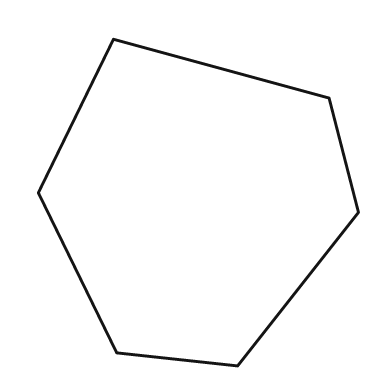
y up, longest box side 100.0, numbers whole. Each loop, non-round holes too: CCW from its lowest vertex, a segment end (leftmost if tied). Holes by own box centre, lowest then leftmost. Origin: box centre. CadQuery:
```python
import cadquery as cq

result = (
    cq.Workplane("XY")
    .moveTo(12.0, -50.0)
    .lineTo(49.0, -3.0)
    .lineTo(40.0, 32.0)
    .lineTo(-26.0, 50.0)
    .lineTo(-49.0, 3.0)
    .lineTo(-25.0, -46.0)
    .close()
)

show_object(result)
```